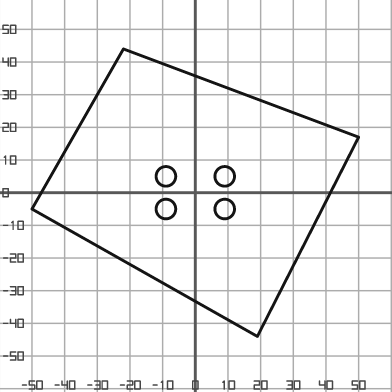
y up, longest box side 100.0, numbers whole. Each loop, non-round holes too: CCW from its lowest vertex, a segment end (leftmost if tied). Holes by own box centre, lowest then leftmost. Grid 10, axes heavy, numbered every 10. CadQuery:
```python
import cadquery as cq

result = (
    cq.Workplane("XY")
    .moveTo(19.0, -44.0)
    .lineTo(50.0, 17.0)
    .lineTo(-22.0, 44.0)
    .lineTo(-50.0, -5.0)
    .close()
    .moveTo(-9.0, -5.0)
    .circle(3.0)
    .moveTo(9.0, -5.0)
    .circle(3.0)
    .moveTo(-9.0, 5.0)
    .circle(3.0)
    .moveTo(9.0, 5.0)
    .circle(3.0)
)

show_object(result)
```